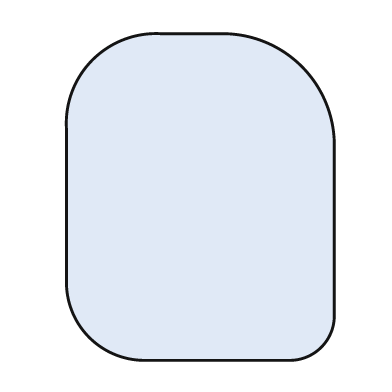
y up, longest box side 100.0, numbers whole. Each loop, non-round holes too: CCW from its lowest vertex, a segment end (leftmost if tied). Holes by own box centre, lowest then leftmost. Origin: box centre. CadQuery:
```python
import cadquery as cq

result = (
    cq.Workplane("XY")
    .moveTo(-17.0, -50.0)
    .lineTo(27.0, -50.0)
    .threePointArc((37.0, -46.0), (41.0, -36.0))
    .lineTo(41.0, 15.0)
    .threePointArc((31.0, 40.0), (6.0, 50.0))
    .lineTo(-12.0, 50.0)
    .threePointArc((-33.0, 42.0), (-41.0, 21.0))
    .lineTo(-41.0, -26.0)
    .threePointArc((-34.0, -43.0), (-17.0, -50.0))
    .close()
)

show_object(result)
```